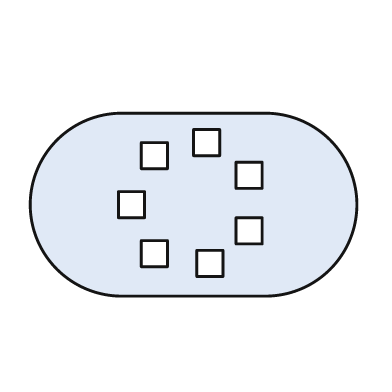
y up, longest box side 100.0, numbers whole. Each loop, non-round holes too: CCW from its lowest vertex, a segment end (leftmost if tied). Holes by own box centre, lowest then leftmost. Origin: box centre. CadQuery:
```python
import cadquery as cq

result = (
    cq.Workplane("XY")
    .moveTo(-22.0, -28.0)
    .lineTo(22.0, -28.0)
    .threePointArc((50.0, 0.0), (22.0, 28.0))
    .lineTo(-22.0, 28.0)
    .threePointArc((-50.0, 0.0), (-22.0, -28.0))
    .close()
    .moveTo(1.0, -22.0)
    .lineTo(9.0, -22.0)
    .lineTo(9.0, -14.0)
    .lineTo(1.0, -14.0)
    .close()
    .moveTo(-16.0, -19.0)
    .lineTo(-8.0, -19.0)
    .lineTo(-8.0, -11.0)
    .lineTo(-16.0, -11.0)
    .close()
    .moveTo(13.0, -12.0)
    .lineTo(21.0, -12.0)
    .lineTo(21.0, -4.0)
    .lineTo(13.0, -4.0)
    .close()
    .moveTo(-23.0, -4.0)
    .lineTo(-15.0, -4.0)
    .lineTo(-15.0, 4.0)
    .lineTo(-23.0, 4.0)
    .close()
    .moveTo(13.0, 5.0)
    .lineTo(21.0, 5.0)
    .lineTo(21.0, 13.0)
    .lineTo(13.0, 13.0)
    .close()
    .moveTo(-16.0, 11.0)
    .lineTo(-8.0, 11.0)
    .lineTo(-8.0, 19.0)
    .lineTo(-16.0, 19.0)
    .close()
    .moveTo(0.0, 15.0)
    .lineTo(8.0, 15.0)
    .lineTo(8.0, 23.0)
    .lineTo(0.0, 23.0)
    .close()
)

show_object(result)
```